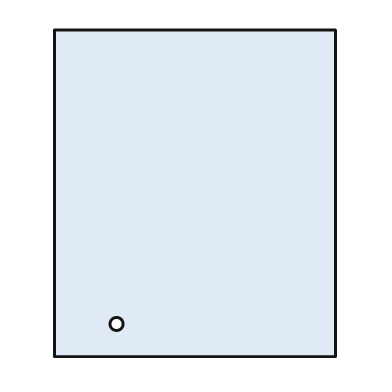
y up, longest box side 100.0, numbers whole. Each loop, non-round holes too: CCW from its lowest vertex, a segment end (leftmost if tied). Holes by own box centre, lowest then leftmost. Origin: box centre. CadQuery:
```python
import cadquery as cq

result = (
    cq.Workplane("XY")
    .moveTo(-43.0, -50.0)
    .lineTo(43.0, -50.0)
    .lineTo(43.0, 50.0)
    .lineTo(-43.0, 50.0)
    .close()
    .moveTo(-24.0, -40.0)
    .circle(2.0)
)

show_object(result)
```